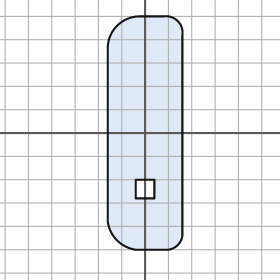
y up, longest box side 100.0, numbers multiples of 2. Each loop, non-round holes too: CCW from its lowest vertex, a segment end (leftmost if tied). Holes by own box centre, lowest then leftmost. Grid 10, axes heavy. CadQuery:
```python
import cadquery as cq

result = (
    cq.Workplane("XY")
    .moveTo(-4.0, -50.0)
    .lineTo(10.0, -50.0)
    .threePointArc((14.0, -48.0), (16.0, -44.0))
    .lineTo(16.0, 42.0)
    .threePointArc((14.0, 48.0), (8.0, 50.0))
    .lineTo(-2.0, 50.0)
    .threePointArc((-12.0, 46.0), (-16.0, 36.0))
    .lineTo(-16.0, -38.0)
    .threePointArc((-12.0, -46.0), (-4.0, -50.0))
    .close()
    .moveTo(-4.0, -28.0)
    .lineTo(4.0, -28.0)
    .lineTo(4.0, -20.0)
    .lineTo(-4.0, -20.0)
    .close()
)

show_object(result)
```